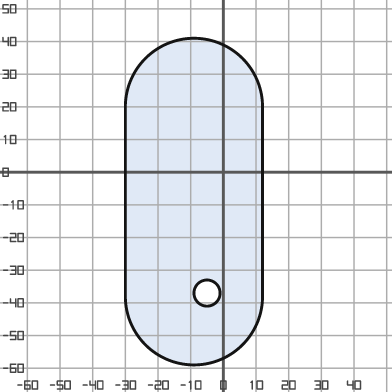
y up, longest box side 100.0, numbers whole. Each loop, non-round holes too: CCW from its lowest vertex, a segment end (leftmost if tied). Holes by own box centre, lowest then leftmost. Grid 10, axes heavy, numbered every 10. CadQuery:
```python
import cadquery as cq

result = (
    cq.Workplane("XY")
    .moveTo(-30.0, -38.0)
    .threePointArc((-9.0, -59.0), (12.0, -38.0))
    .lineTo(12.0, 20.0)
    .threePointArc((-9.0, 41.0), (-30.0, 20.0))
    .close()
    .moveTo(-5.0, -37.0)
    .circle(4.0)
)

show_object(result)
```